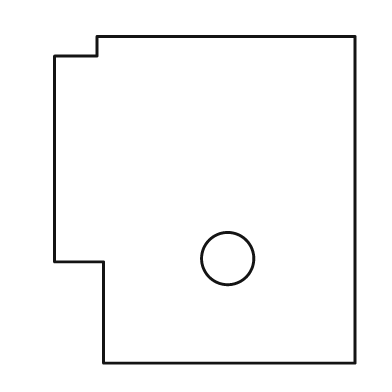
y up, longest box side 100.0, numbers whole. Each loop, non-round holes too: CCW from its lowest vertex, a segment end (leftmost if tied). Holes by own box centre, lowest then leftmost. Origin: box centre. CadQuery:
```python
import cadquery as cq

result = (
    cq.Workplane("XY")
    .moveTo(-31.0, -50.0)
    .lineTo(46.0, -50.0)
    .lineTo(46.0, 50.0)
    .lineTo(-33.0, 50.0)
    .lineTo(-33.0, 44.0)
    .lineTo(-46.0, 44.0)
    .lineTo(-46.0, -19.0)
    .lineTo(-31.0, -19.0)
    .close()
    .moveTo(7.0, -18.0)
    .circle(8.0)
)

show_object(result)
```